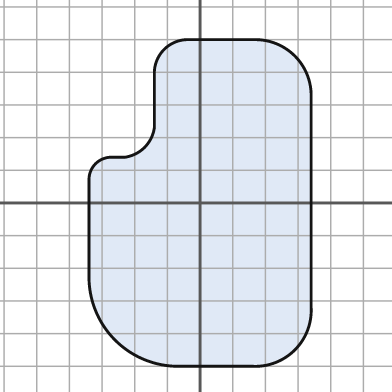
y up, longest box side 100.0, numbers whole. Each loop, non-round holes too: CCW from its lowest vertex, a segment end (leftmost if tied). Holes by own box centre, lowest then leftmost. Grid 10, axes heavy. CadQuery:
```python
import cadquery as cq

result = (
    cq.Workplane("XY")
    .moveTo(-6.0, -50.0)
    .lineTo(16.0, -50.0)
    .threePointArc((29.0, -45.0), (34.0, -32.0))
    .lineTo(34.0, 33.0)
    .threePointArc((29.0, 45.0), (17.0, 50.0))
    .lineTo(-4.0, 50.0)
    .threePointArc((-11.0, 47.0), (-14.0, 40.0))
    .lineTo(-14.0, 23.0)
    .threePointArc((-17.0, 17.0), (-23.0, 14.0))
    .lineTo(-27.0, 14.0)
    .threePointArc((-32.0, 12.0), (-34.0, 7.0))
    .lineTo(-34.0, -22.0)
    .threePointArc((-26.0, -42.0), (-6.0, -50.0))
    .close()
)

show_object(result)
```